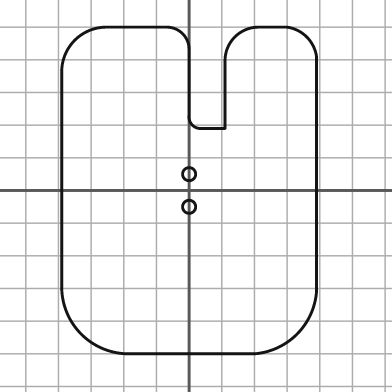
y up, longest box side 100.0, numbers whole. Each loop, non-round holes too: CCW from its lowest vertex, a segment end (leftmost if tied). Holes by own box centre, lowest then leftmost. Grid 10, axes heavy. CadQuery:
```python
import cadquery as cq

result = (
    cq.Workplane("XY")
    .moveTo(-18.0, -50.0)
    .lineTo(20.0, -50.0)
    .threePointArc((33.0, -44.0), (39.0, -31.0))
    .lineTo(39.0, 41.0)
    .threePointArc((36.0, 47.0), (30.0, 50.0))
    .lineTo(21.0, 50.0)
    .threePointArc((14.0, 47.0), (11.0, 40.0))
    .lineTo(11.0, 19.0)
    .lineTo(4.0, 19.0)
    .threePointArc((1.0, 20.0), (0.0, 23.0))
    .lineTo(0.0, 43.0)
    .threePointArc((-2.0, 48.0), (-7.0, 50.0))
    .lineTo(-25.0, 50.0)
    .threePointArc((-35.0, 46.0), (-39.0, 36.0))
    .lineTo(-39.0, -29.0)
    .threePointArc((-33.0, -44.0), (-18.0, -50.0))
    .close()
    .moveTo(0.0, -5.0)
    .circle(2.0)
    .moveTo(0.0, 5.0)
    .circle(2.0)
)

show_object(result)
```